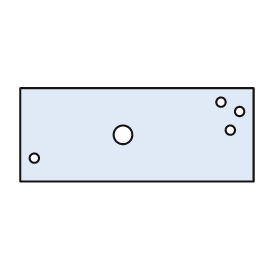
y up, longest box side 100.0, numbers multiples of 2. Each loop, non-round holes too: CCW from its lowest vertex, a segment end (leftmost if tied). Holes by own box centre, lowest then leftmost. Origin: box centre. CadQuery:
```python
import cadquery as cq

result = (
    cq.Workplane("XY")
    .moveTo(-50.0, -20.0)
    .lineTo(50.0, -20.0)
    .lineTo(50.0, 20.0)
    .lineTo(-50.0, 20.0)
    .close()
    .moveTo(-44.0, -10.0)
    .circle(2.0)
    .moveTo(-6.0, 0.0)
    .circle(4.0)
    .moveTo(40.0, 2.0)
    .circle(2.0)
    .moveTo(44.0, 10.0)
    .circle(2.0)
    .moveTo(36.0, 14.0)
    .circle(2.0)
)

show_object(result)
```